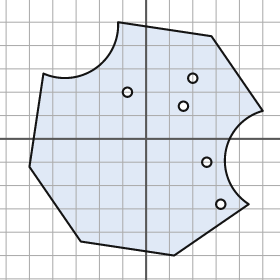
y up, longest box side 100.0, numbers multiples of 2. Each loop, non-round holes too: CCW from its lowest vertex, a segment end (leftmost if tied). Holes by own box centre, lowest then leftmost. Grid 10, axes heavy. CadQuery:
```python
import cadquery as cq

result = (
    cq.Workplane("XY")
    .moveTo(12.0, -50.0)
    .lineTo(44.0, -28.0)
    .threePointArc((34.0, -6.0), (50.0, 12.0))
    .lineTo(28.0, 44.0)
    .lineTo(-12.0, 50.0)
    .threePointArc((-22.0, 30.0), (-44.0, 28.0))
    .lineTo(-50.0, -12.0)
    .lineTo(-28.0, -44.0)
    .close()
    .moveTo(32.0, -28.0)
    .circle(2.0)
    .moveTo(26.0, -10.0)
    .circle(2.0)
    .moveTo(16.0, 14.0)
    .circle(2.0)
    .moveTo(-8.0, 20.0)
    .circle(2.0)
    .moveTo(20.0, 26.0)
    .circle(2.0)
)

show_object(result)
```